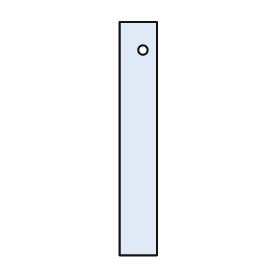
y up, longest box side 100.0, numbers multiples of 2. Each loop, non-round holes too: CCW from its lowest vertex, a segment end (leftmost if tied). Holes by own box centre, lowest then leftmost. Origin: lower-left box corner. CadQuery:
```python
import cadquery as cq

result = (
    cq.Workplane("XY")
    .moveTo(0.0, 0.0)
    .lineTo(16.0, 0.0)
    .lineTo(16.0, 100.0)
    .lineTo(0.0, 100.0)
    .close()
    .moveTo(10.0, 88.0)
    .circle(2.0)
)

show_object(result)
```